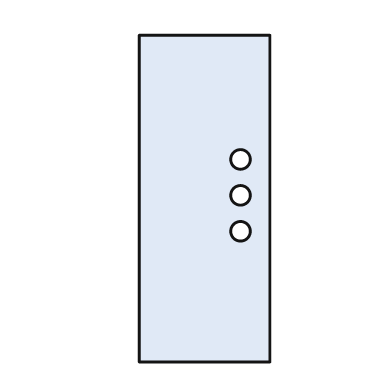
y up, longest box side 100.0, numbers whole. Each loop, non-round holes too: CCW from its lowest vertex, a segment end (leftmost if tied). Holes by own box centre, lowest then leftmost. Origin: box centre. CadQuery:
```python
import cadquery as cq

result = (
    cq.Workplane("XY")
    .moveTo(-20.0, -50.0)
    .lineTo(20.0, -50.0)
    .lineTo(20.0, 50.0)
    .lineTo(-20.0, 50.0)
    .close()
    .moveTo(11.0, -10.0)
    .circle(3.0)
    .moveTo(11.0, 1.0)
    .circle(3.0)
    .moveTo(11.0, 12.0)
    .circle(3.0)
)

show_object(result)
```